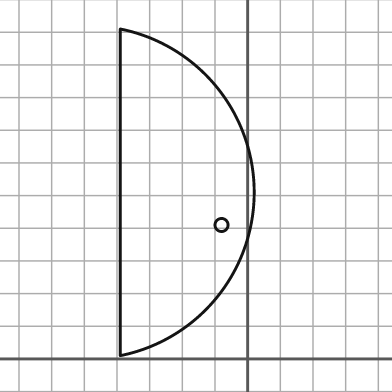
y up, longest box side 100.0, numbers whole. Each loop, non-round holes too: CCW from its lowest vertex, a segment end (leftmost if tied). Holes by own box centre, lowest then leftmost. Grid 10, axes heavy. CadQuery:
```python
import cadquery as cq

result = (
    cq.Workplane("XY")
    .moveTo(-39.0, 1.0)
    .threePointArc((2.0, 51.0), (-39.0, 101.0))
    .close()
    .moveTo(-8.0, 41.0)
    .circle(2.0)
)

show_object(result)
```